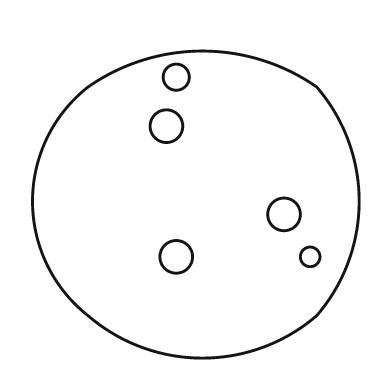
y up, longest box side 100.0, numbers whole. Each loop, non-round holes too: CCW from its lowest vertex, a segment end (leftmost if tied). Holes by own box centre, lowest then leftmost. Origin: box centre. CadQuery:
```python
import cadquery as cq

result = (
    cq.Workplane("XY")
    .moveTo(-33.0, -34.0)
    .threePointArc((2.0, -47.0), (37.0, -34.0))
    .threePointArc((50.0, 1.0), (37.0, 36.0))
    .threePointArc((2.0, 47.0), (-33.0, 36.0))
    .threePointArc((-50.0, 1.0), (-33.0, -34.0))
    .close()
    .moveTo(-6.0, -16.0)
    .circle(5.0)
    .moveTo(35.0, -16.0)
    .circle(3.0)
    .moveTo(27.0, -3.0)
    .circle(5.0)
    .moveTo(-9.0, 24.0)
    .circle(5.0)
    .moveTo(-6.0, 39.0)
    .circle(4.0)
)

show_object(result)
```